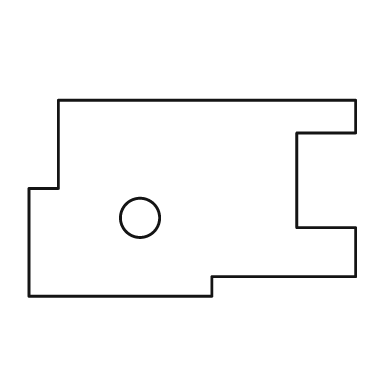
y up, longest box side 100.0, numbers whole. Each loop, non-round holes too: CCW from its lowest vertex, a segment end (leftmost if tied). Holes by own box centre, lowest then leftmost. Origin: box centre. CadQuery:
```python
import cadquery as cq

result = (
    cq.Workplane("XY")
    .moveTo(-50.0, -30.0)
    .lineTo(6.0, -30.0)
    .lineTo(6.0, -24.0)
    .lineTo(50.0, -24.0)
    .lineTo(50.0, -9.0)
    .lineTo(32.0, -9.0)
    .lineTo(32.0, 20.0)
    .lineTo(50.0, 20.0)
    .lineTo(50.0, 30.0)
    .lineTo(-41.0, 30.0)
    .lineTo(-41.0, 3.0)
    .lineTo(-50.0, 3.0)
    .close()
    .moveTo(-16.0, -6.0)
    .circle(6.0)
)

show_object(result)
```